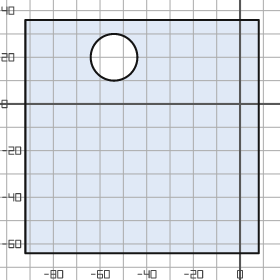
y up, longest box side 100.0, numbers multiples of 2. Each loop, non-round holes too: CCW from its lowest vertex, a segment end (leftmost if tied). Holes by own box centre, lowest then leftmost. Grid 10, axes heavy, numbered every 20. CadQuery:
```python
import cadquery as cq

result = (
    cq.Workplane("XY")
    .moveTo(-92.0, -64.0)
    .lineTo(8.0, -64.0)
    .lineTo(8.0, 36.0)
    .lineTo(-92.0, 36.0)
    .close()
    .moveTo(-54.0, 20.0)
    .circle(10.0)
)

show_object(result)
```